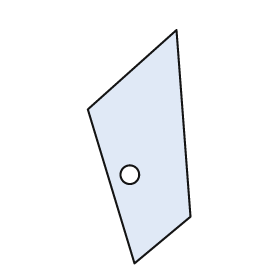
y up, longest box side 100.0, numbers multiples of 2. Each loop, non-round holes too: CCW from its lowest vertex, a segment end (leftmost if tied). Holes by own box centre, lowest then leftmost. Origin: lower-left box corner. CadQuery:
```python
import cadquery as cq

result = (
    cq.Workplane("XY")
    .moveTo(20.0, 0.0)
    .lineTo(44.0, 20.0)
    .lineTo(38.0, 100.0)
    .lineTo(0.0, 66.0)
    .close()
    .moveTo(18.0, 38.0)
    .circle(4.0)
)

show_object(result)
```